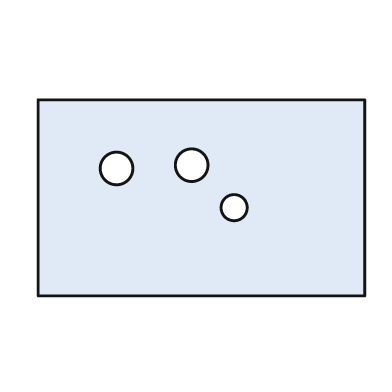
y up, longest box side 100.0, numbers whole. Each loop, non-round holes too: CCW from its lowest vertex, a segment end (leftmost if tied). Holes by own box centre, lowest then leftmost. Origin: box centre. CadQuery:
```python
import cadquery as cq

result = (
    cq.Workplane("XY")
    .moveTo(-50.0, -30.0)
    .lineTo(50.0, -30.0)
    .lineTo(50.0, 30.0)
    .lineTo(-50.0, 30.0)
    .close()
    .moveTo(10.0, -3.0)
    .circle(4.0)
    .moveTo(-26.0, 9.0)
    .circle(5.0)
    .moveTo(-3.0, 10.0)
    .circle(5.0)
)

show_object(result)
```